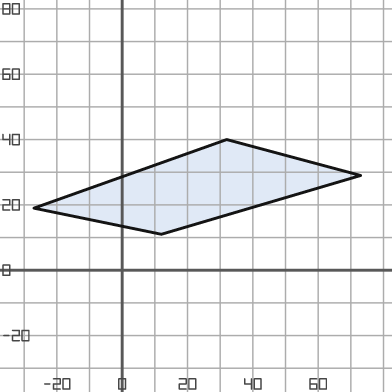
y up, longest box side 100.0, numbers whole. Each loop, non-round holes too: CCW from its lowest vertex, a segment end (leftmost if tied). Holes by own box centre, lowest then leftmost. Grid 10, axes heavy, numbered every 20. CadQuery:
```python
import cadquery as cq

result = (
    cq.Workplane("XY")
    .moveTo(12.0, 11.0)
    .lineTo(73.0, 29.0)
    .lineTo(32.0, 40.0)
    .lineTo(-27.0, 19.0)
    .close()
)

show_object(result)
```